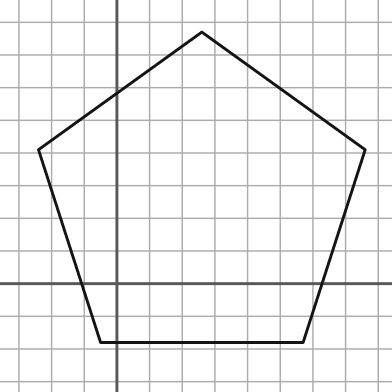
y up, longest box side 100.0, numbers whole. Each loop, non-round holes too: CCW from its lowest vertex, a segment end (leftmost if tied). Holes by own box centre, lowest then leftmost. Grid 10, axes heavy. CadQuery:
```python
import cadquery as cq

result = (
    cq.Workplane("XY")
    .moveTo(-5.0, -18.0)
    .lineTo(57.0, -18.0)
    .lineTo(76.0, 41.0)
    .lineTo(26.0, 77.0)
    .lineTo(-24.0, 41.0)
    .close()
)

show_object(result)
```